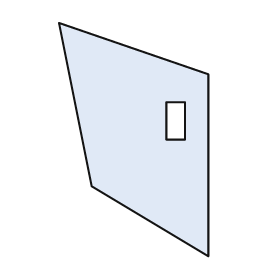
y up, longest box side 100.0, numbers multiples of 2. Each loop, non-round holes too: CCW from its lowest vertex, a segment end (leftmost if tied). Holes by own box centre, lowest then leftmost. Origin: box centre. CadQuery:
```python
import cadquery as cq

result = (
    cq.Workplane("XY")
    .moveTo(32.0, -50.0)
    .lineTo(32.0, 28.0)
    .lineTo(-32.0, 50.0)
    .lineTo(-18.0, -20.0)
    .close()
    .moveTo(14.0, 0.0)
    .lineTo(22.0, 0.0)
    .lineTo(22.0, 16.0)
    .lineTo(14.0, 16.0)
    .close()
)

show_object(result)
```